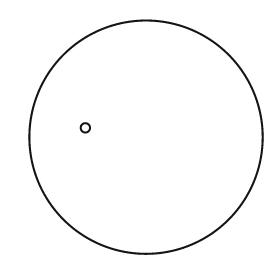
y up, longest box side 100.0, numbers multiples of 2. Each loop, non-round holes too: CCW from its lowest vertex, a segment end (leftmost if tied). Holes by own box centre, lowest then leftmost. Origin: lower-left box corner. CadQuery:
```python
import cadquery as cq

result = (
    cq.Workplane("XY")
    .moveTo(50.0, 50.0)
    .circle(50.0)
    .moveTo(24.0, 54.0)
    .circle(2.0)
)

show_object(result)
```